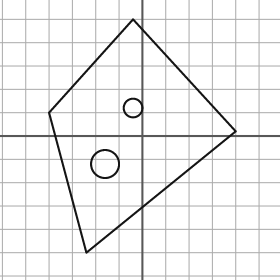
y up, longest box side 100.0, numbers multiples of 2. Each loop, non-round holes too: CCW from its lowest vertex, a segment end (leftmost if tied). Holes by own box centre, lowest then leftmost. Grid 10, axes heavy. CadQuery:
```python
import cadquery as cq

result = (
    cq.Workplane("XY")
    .moveTo(-24.0, -50.0)
    .lineTo(40.0, 2.0)
    .lineTo(-4.0, 50.0)
    .lineTo(-40.0, 10.0)
    .close()
    .moveTo(-16.0, -12.0)
    .circle(6.0)
    .moveTo(-4.0, 12.0)
    .circle(4.0)
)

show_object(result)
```